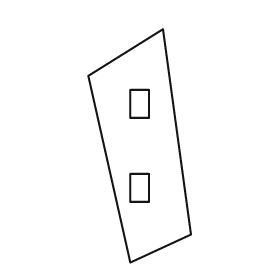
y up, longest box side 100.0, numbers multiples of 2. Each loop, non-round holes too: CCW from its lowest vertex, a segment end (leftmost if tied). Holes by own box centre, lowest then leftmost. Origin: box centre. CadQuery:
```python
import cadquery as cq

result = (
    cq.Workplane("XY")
    .moveTo(-4.0, -50.0)
    .lineTo(22.0, -38.0)
    .lineTo(10.0, 50.0)
    .lineTo(-22.0, 30.0)
    .close()
    .moveTo(-4.0, -24.0)
    .lineTo(4.0, -24.0)
    .lineTo(4.0, -12.0)
    .lineTo(-4.0, -12.0)
    .close()
    .moveTo(-4.0, 12.0)
    .lineTo(4.0, 12.0)
    .lineTo(4.0, 24.0)
    .lineTo(-4.0, 24.0)
    .close()
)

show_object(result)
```